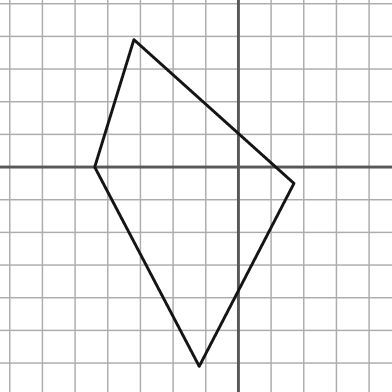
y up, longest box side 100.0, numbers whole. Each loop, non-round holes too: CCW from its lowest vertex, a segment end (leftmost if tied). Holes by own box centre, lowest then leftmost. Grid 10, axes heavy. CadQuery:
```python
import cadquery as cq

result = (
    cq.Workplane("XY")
    .moveTo(-12.0, -61.0)
    .lineTo(17.0, -5.0)
    .lineTo(-32.0, 39.0)
    .lineTo(-44.0, 0.0)
    .close()
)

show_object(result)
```